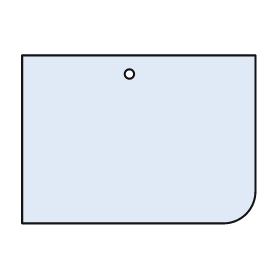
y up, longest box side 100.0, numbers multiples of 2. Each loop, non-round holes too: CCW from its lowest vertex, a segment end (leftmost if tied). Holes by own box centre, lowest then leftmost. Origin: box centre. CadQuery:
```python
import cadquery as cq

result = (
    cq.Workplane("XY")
    .moveTo(-50.0, -36.0)
    .lineTo(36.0, -36.0)
    .threePointArc((46.0, -32.0), (50.0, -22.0))
    .lineTo(50.0, 36.0)
    .lineTo(-50.0, 36.0)
    .close()
    .moveTo(-4.0, 28.0)
    .circle(2.0)
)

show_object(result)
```